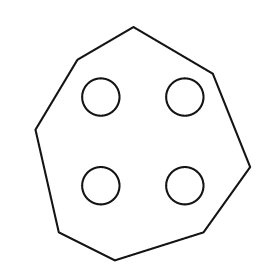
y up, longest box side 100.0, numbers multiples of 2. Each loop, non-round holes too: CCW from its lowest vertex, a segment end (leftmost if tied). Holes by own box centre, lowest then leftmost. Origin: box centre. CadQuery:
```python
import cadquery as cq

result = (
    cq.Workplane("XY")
    .moveTo(-12.0, -50.0)
    .lineTo(26.0, -38.0)
    .lineTo(46.0, -10.0)
    .lineTo(30.0, 30.0)
    .lineTo(-4.0, 50.0)
    .lineTo(-28.0, 36.0)
    .lineTo(-46.0, 6.0)
    .lineTo(-36.0, -38.0)
    .close()
    .moveTo(-18.0, -18.0)
    .circle(8.0)
    .moveTo(18.0, -18.0)
    .circle(8.0)
    .moveTo(-18.0, 20.0)
    .circle(8.0)
    .moveTo(18.0, 20.0)
    .circle(8.0)
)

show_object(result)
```